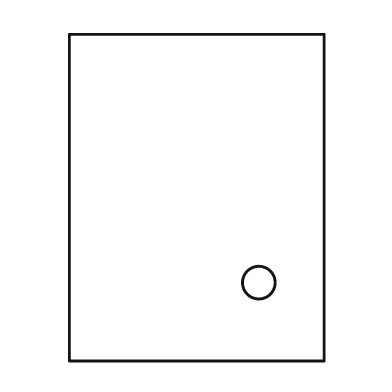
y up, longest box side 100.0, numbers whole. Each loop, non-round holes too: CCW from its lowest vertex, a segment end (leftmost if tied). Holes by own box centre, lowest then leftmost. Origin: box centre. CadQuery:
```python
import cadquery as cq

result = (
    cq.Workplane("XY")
    .moveTo(-39.0, -50.0)
    .lineTo(39.0, -50.0)
    .lineTo(39.0, 50.0)
    .lineTo(-39.0, 50.0)
    .close()
    .moveTo(19.0, -26.0)
    .circle(5.0)
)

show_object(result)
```